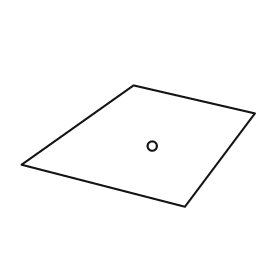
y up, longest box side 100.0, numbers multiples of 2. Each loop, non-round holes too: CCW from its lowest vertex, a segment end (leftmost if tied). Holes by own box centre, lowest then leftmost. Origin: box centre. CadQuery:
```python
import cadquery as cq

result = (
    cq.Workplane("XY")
    .moveTo(20.0, -26.0)
    .lineTo(50.0, 14.0)
    .lineTo(-2.0, 26.0)
    .lineTo(-50.0, -8.0)
    .close()
    .moveTo(6.0, 0.0)
    .circle(2.0)
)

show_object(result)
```